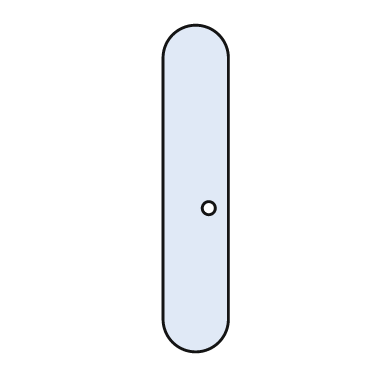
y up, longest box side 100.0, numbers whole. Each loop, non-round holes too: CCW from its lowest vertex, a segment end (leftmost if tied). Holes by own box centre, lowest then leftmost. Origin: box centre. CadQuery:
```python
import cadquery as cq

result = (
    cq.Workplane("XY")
    .moveTo(-10.0, -40.0)
    .threePointArc((0.0, -50.0), (10.0, -40.0))
    .lineTo(10.0, 40.0)
    .threePointArc((0.0, 50.0), (-10.0, 40.0))
    .close()
    .moveTo(4.0, -6.0)
    .circle(2.0)
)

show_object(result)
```